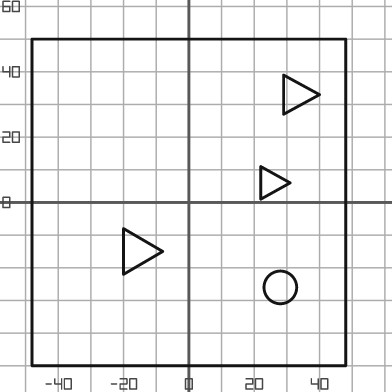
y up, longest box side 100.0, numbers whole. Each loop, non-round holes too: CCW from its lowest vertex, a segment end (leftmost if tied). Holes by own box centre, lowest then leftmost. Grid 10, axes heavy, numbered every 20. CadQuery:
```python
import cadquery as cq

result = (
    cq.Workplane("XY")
    .moveTo(-48.0, -50.0)
    .lineTo(48.0, -50.0)
    .lineTo(48.0, 50.0)
    .lineTo(-48.0, 50.0)
    .close()
    .moveTo(28.0, -26.0)
    .circle(5.0)
    .moveTo(-20.0, -22.0)
    .lineTo(-8.0, -15.0)
    .lineTo(-20.0, -8.0)
    .close()
    .moveTo(22.0, 1.0)
    .lineTo(31.0, 6.0)
    .lineTo(22.0, 11.0)
    .close()
    .moveTo(29.0, 27.0)
    .lineTo(40.0, 33.0)
    .lineTo(29.0, 39.0)
    .close()
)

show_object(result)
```